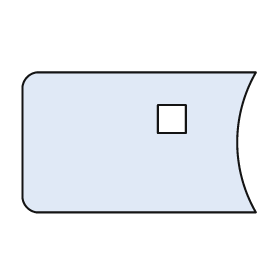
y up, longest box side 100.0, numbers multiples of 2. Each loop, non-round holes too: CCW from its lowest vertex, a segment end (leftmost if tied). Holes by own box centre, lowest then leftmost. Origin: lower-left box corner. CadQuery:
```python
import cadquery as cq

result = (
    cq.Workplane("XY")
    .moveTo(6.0, 0.0)
    .lineTo(100.0, 0.0)
    .threePointArc((92.0, 30.0), (100.0, 60.0))
    .lineTo(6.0, 60.0)
    .threePointArc((2.0, 58.0), (0.0, 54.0))
    .lineTo(0.0, 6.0)
    .threePointArc((2.0, 2.0), (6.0, 0.0))
    .close()
    .moveTo(58.0, 34.0)
    .lineTo(70.0, 34.0)
    .lineTo(70.0, 46.0)
    .lineTo(58.0, 46.0)
    .close()
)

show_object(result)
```